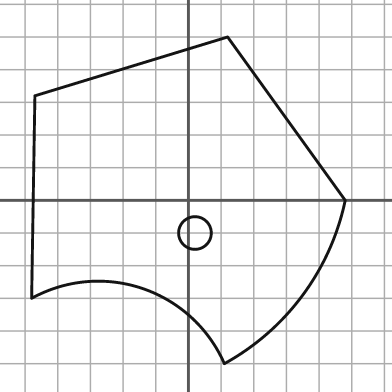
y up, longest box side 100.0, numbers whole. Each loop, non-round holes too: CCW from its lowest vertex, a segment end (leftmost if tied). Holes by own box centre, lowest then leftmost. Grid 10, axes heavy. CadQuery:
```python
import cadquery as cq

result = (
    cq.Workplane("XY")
    .moveTo(11.0, -50.0)
    .threePointArc((35.0, -29.0), (48.0, 0.0))
    .lineTo(12.0, 50.0)
    .lineTo(-47.0, 32.0)
    .lineTo(-48.0, -30.0)
    .threePointArc((-14.0, -27.0), (11.0, -50.0))
    .close()
    .moveTo(2.0, -10.0)
    .circle(5.0)
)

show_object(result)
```